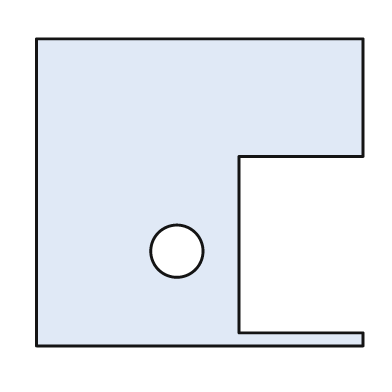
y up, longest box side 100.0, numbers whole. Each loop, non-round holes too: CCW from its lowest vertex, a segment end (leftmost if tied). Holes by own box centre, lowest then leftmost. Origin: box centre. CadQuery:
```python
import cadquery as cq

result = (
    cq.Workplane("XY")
    .moveTo(-50.0, -47.0)
    .lineTo(50.0, -47.0)
    .lineTo(50.0, -43.0)
    .lineTo(12.0, -43.0)
    .lineTo(12.0, 11.0)
    .lineTo(50.0, 11.0)
    .lineTo(50.0, 47.0)
    .lineTo(-50.0, 47.0)
    .close()
    .moveTo(-7.0, -18.0)
    .circle(8.0)
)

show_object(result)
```